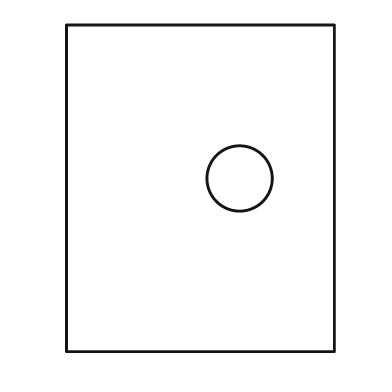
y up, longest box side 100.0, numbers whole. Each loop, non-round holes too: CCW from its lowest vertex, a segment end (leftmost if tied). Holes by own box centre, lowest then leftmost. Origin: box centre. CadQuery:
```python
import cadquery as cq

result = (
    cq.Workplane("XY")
    .moveTo(-41.0, -50.0)
    .lineTo(41.0, -50.0)
    .lineTo(41.0, 50.0)
    .lineTo(-41.0, 50.0)
    .close()
    .moveTo(12.0, 3.0)
    .circle(10.0)
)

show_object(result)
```